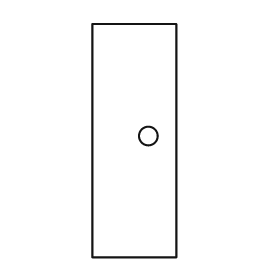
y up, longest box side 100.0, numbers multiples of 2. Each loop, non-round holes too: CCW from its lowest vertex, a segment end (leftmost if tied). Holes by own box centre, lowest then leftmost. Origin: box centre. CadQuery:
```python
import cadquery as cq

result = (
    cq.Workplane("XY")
    .moveTo(-18.0, -50.0)
    .lineTo(18.0, -50.0)
    .lineTo(18.0, 50.0)
    .lineTo(-18.0, 50.0)
    .close()
    .moveTo(6.0, 2.0)
    .circle(4.0)
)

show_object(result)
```